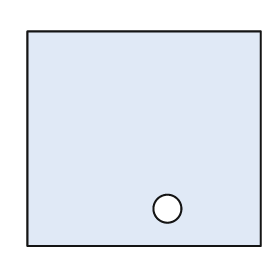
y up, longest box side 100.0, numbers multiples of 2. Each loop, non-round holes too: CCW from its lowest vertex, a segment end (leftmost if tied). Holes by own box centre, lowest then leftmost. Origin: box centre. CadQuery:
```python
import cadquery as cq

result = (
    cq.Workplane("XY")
    .moveTo(-50.0, -46.0)
    .lineTo(50.0, -46.0)
    .lineTo(50.0, 46.0)
    .lineTo(-50.0, 46.0)
    .close()
    .moveTo(10.0, -30.0)
    .circle(6.0)
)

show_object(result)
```